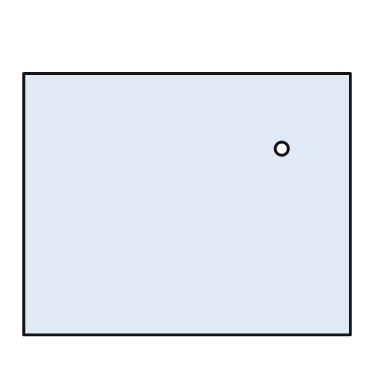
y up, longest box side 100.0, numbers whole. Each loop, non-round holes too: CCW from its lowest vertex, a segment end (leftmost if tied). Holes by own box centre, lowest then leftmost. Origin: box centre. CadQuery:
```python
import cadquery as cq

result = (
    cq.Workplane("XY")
    .moveTo(-50.0, -40.0)
    .lineTo(50.0, -40.0)
    .lineTo(50.0, 40.0)
    .lineTo(-50.0, 40.0)
    .close()
    .moveTo(29.0, 17.0)
    .circle(2.0)
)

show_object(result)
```